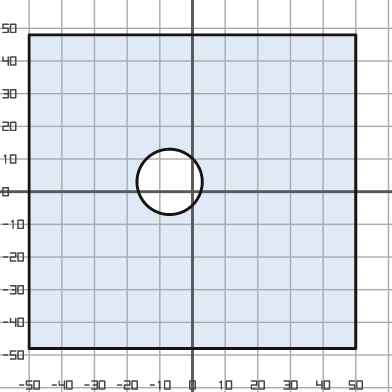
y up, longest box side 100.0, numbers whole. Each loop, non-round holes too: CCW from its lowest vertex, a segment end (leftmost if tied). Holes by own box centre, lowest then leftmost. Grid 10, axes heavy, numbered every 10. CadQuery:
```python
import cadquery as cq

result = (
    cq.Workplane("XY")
    .moveTo(-50.0, -48.0)
    .lineTo(50.0, -48.0)
    .lineTo(50.0, 48.0)
    .lineTo(-50.0, 48.0)
    .close()
    .moveTo(-7.0, 3.0)
    .circle(10.0)
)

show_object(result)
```